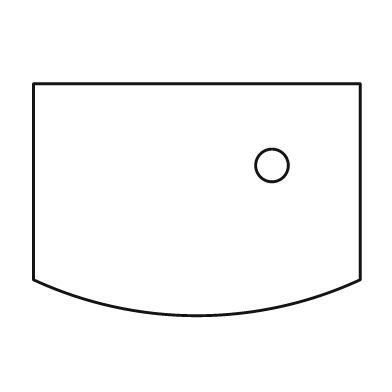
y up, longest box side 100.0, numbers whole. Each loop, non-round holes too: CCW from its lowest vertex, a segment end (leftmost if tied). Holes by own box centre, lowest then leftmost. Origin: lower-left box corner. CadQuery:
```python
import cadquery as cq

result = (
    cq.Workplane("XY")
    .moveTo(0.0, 11.0)
    .threePointArc((50.0, 0.0), (100.0, 11.0))
    .lineTo(100.0, 71.0)
    .lineTo(0.0, 71.0)
    .close()
    .moveTo(73.0, 46.0)
    .circle(5.0)
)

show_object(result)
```